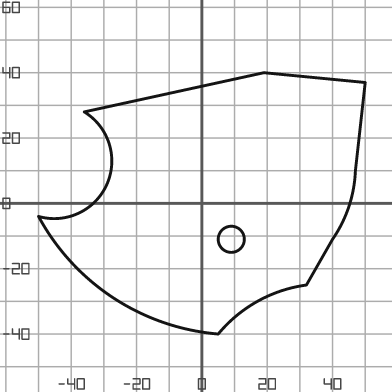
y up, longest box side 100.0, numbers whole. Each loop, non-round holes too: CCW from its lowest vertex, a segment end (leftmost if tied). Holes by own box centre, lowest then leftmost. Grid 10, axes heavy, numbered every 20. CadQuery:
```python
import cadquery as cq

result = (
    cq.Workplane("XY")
    .moveTo(5.0, -40.0)
    .threePointArc((17.0, -30.0), (32.0, -25.0))
    .lineTo(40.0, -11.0)
    .threePointArc((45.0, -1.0), (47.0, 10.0))
    .lineTo(50.0, 37.0)
    .lineTo(19.0, 40.0)
    .lineTo(-36.0, 28.0)
    .threePointArc((-29.0, 6.0), (-50.0, -4.0))
    .threePointArc((-27.0, -29.0), (5.0, -40.0))
    .close()
    .moveTo(9.0, -11.0)
    .circle(4.0)
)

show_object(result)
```